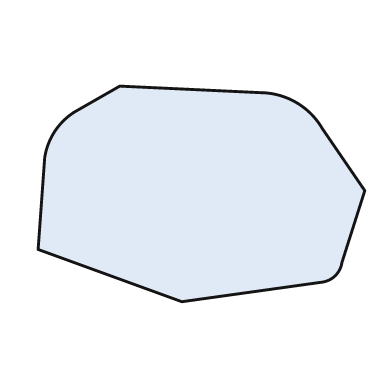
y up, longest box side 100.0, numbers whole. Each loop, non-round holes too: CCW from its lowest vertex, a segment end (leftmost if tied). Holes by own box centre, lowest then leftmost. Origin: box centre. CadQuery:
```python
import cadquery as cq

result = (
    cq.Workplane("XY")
    .moveTo(-6.0, -33.0)
    .lineTo(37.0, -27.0)
    .threePointArc((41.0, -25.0), (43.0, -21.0))
    .lineTo(50.0, 1.0)
    .lineTo(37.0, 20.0)
    .threePointArc((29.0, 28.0), (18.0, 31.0))
    .lineTo(-25.0, 33.0)
    .lineTo(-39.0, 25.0)
    .threePointArc((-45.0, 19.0), (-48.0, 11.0))
    .lineTo(-50.0, -17.0)
    .close()
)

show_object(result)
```